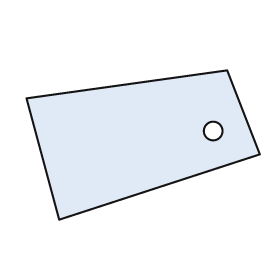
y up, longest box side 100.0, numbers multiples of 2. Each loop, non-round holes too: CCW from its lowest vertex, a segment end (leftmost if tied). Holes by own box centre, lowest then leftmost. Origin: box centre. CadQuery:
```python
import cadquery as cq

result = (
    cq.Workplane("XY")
    .moveTo(-36.0, -32.0)
    .lineTo(50.0, -4.0)
    .lineTo(36.0, 32.0)
    .lineTo(-50.0, 20.0)
    .close()
    .moveTo(30.0, 6.0)
    .circle(4.0)
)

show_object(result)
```